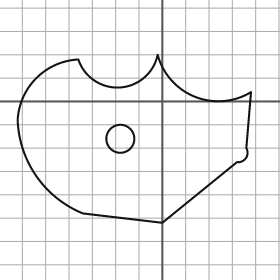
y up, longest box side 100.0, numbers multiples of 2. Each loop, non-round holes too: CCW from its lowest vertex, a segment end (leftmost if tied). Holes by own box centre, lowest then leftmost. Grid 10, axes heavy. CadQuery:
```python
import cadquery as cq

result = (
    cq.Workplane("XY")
    .moveTo(0.0, -52.0)
    .lineTo(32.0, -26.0)
    .threePointArc((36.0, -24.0), (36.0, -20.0))
    .lineTo(38.0, 4.0)
    .threePointArc((14.0, 2.0), (-2.0, 20.0))
    .threePointArc((-18.0, 6.0), (-36.0, 18.0))
    .threePointArc((-54.0, 10.0), (-62.0, -8.0))
    .threePointArc((-54.0, -32.0), (-34.0, -48.0))
    .close()
    .moveTo(-18.0, -16.0)
    .circle(6.0)
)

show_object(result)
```